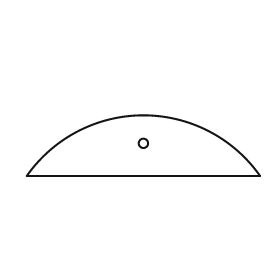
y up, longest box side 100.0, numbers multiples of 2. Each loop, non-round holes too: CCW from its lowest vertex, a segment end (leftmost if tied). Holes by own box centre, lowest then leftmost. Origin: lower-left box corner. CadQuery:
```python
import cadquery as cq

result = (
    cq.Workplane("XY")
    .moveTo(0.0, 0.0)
    .lineTo(100.0, 0.0)
    .threePointArc((50.0, 26.0), (0.0, 0.0))
    .close()
    .moveTo(50.0, 14.0)
    .circle(2.0)
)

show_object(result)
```